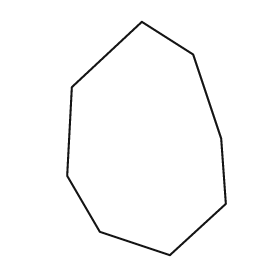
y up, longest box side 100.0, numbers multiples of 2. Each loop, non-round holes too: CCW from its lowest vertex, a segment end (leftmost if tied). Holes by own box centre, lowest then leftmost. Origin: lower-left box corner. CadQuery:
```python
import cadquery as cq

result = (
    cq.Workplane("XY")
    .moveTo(44.0, 0.0)
    .lineTo(68.0, 22.0)
    .lineTo(66.0, 50.0)
    .lineTo(54.0, 86.0)
    .lineTo(32.0, 100.0)
    .lineTo(2.0, 72.0)
    .lineTo(0.0, 34.0)
    .lineTo(14.0, 10.0)
    .close()
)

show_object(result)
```